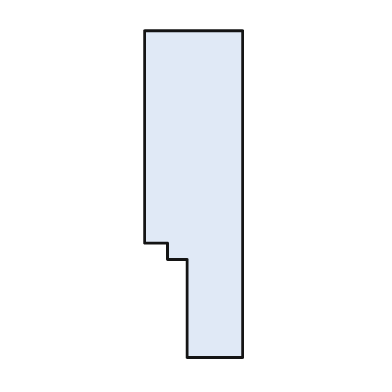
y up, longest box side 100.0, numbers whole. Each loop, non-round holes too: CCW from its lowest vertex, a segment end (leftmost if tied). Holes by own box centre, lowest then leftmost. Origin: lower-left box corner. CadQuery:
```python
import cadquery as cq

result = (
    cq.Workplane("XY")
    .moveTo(13.0, 0.0)
    .lineTo(30.0, 0.0)
    .lineTo(30.0, 100.0)
    .lineTo(0.0, 100.0)
    .lineTo(0.0, 35.0)
    .lineTo(7.0, 35.0)
    .lineTo(7.0, 30.0)
    .lineTo(13.0, 30.0)
    .close()
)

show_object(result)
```